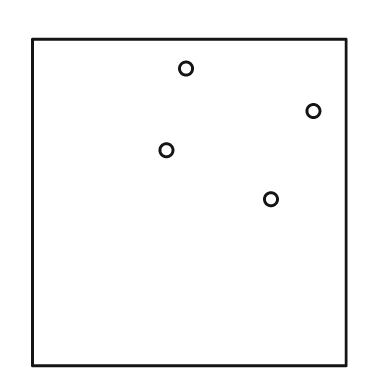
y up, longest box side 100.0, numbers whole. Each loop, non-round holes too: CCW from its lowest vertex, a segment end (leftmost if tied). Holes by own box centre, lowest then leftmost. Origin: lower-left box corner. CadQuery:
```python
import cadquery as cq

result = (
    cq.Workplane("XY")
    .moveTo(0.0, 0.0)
    .lineTo(96.0, 0.0)
    .lineTo(96.0, 100.0)
    .lineTo(0.0, 100.0)
    .close()
    .moveTo(73.0, 51.0)
    .circle(2.0)
    .moveTo(41.0, 66.0)
    .circle(2.0)
    .moveTo(86.0, 78.0)
    .circle(2.0)
    .moveTo(47.0, 91.0)
    .circle(2.0)
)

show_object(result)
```